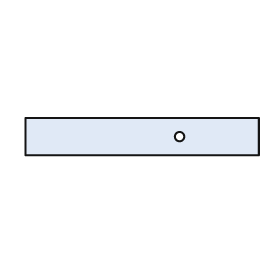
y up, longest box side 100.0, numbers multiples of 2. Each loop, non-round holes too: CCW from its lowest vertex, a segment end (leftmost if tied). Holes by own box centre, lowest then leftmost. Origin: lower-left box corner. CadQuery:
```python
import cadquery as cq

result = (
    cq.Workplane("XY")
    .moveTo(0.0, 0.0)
    .lineTo(100.0, 0.0)
    .lineTo(100.0, 16.0)
    .lineTo(0.0, 16.0)
    .close()
    .moveTo(66.0, 8.0)
    .circle(2.0)
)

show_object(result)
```